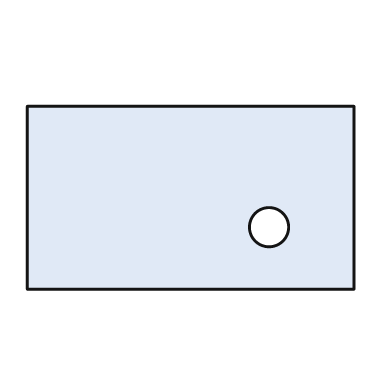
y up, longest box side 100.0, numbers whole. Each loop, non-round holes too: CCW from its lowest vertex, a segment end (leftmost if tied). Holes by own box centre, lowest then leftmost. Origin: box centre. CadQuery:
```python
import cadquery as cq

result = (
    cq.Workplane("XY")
    .moveTo(-50.0, -28.0)
    .lineTo(50.0, -28.0)
    .lineTo(50.0, 28.0)
    .lineTo(-50.0, 28.0)
    .close()
    .moveTo(24.0, -9.0)
    .circle(6.0)
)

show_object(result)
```